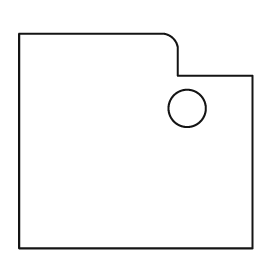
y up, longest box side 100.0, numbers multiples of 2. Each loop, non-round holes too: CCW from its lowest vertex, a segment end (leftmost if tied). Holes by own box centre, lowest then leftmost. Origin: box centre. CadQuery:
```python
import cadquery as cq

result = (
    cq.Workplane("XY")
    .moveTo(-50.0, -46.0)
    .lineTo(50.0, -46.0)
    .lineTo(50.0, 28.0)
    .lineTo(18.0, 28.0)
    .lineTo(18.0, 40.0)
    .threePointArc((16.0, 44.0), (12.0, 46.0))
    .lineTo(-50.0, 46.0)
    .close()
    .moveTo(22.0, 14.0)
    .circle(8.0)
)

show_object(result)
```